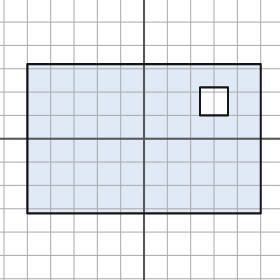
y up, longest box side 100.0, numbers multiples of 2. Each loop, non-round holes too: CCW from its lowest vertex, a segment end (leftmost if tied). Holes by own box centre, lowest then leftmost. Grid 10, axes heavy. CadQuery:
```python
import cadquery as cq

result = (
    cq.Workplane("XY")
    .moveTo(-50.0, -32.0)
    .lineTo(50.0, -32.0)
    .lineTo(50.0, 32.0)
    .lineTo(-50.0, 32.0)
    .close()
    .moveTo(24.0, 10.0)
    .lineTo(36.0, 10.0)
    .lineTo(36.0, 22.0)
    .lineTo(24.0, 22.0)
    .close()
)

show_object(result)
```